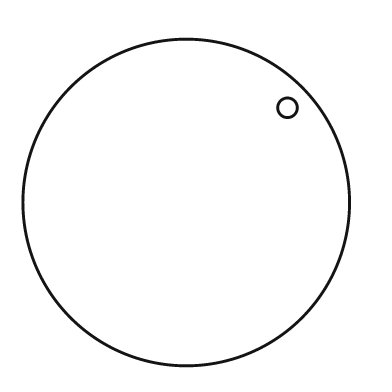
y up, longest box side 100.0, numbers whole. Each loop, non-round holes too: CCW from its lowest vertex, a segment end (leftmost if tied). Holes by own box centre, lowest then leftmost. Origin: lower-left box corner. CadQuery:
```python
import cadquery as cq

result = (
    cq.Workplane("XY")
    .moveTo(50.0, 50.0)
    .circle(50.0)
    .moveTo(81.0, 79.0)
    .circle(3.0)
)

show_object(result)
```